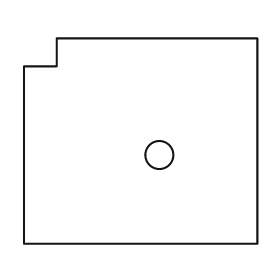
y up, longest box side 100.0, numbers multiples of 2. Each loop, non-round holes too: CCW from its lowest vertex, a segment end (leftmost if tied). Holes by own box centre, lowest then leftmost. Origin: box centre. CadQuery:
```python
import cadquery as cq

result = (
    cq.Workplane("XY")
    .moveTo(-50.0, -44.0)
    .lineTo(50.0, -44.0)
    .lineTo(50.0, 44.0)
    .lineTo(-36.0, 44.0)
    .lineTo(-36.0, 32.0)
    .lineTo(-50.0, 32.0)
    .close()
    .moveTo(8.0, -6.0)
    .circle(6.0)
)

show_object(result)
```